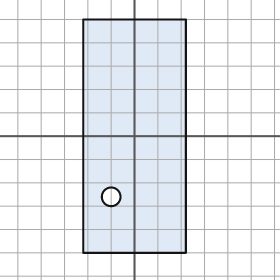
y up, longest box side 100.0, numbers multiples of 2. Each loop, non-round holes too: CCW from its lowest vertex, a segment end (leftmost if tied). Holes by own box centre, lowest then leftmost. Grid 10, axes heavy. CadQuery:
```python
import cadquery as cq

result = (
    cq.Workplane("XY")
    .moveTo(-22.0, -50.0)
    .lineTo(22.0, -50.0)
    .lineTo(22.0, 50.0)
    .lineTo(-22.0, 50.0)
    .close()
    .moveTo(-10.0, -26.0)
    .circle(4.0)
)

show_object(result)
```